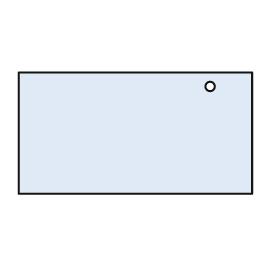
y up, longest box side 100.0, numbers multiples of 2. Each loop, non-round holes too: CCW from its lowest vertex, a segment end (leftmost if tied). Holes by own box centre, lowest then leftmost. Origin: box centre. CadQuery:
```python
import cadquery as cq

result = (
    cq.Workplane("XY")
    .moveTo(-50.0, -26.0)
    .lineTo(50.0, -26.0)
    .lineTo(50.0, 26.0)
    .lineTo(-50.0, 26.0)
    .close()
    .moveTo(32.0, 20.0)
    .circle(2.0)
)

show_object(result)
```